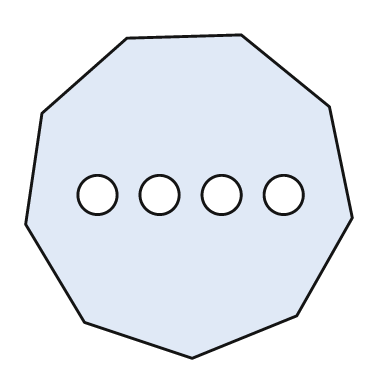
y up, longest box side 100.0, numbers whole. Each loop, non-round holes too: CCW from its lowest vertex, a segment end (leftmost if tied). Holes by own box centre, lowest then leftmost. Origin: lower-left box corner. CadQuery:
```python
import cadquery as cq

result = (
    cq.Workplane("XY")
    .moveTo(51.0, 0.0)
    .lineTo(83.0, 13.0)
    .lineTo(100.0, 43.0)
    .lineTo(93.0, 77.0)
    .lineTo(66.0, 99.0)
    .lineTo(31.0, 98.0)
    .lineTo(5.0, 75.0)
    .lineTo(0.0, 41.0)
    .lineTo(18.0, 11.0)
    .close()
    .moveTo(22.0, 50.0)
    .circle(6.0)
    .moveTo(41.0, 50.0)
    .circle(6.0)
    .moveTo(60.0, 50.0)
    .circle(6.0)
    .moveTo(79.0, 50.0)
    .circle(6.0)
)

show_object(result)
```